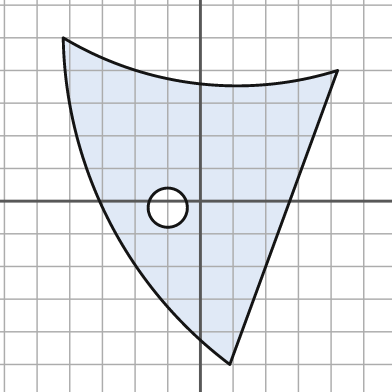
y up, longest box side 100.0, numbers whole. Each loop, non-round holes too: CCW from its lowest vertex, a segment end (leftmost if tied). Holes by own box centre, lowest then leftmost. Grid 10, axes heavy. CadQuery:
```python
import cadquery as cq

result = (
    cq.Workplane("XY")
    .moveTo(9.0, -50.0)
    .lineTo(42.0, 40.0)
    .threePointArc((-1.0, 36.0), (-42.0, 50.0))
    .threePointArc((-28.0, -6.0), (9.0, -50.0))
    .close()
    .moveTo(-10.0, -2.0)
    .circle(6.0)
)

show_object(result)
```